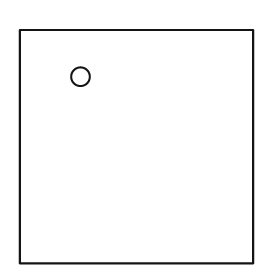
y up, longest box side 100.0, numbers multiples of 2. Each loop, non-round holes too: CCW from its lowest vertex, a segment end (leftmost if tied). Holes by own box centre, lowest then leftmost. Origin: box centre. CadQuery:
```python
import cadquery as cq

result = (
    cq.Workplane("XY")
    .moveTo(-50.0, -50.0)
    .lineTo(50.0, -50.0)
    .lineTo(50.0, 50.0)
    .lineTo(-50.0, 50.0)
    .close()
    .moveTo(-24.0, 30.0)
    .circle(4.0)
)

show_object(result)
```